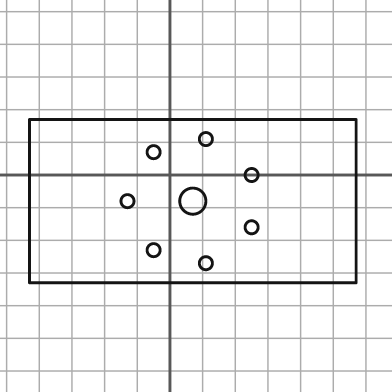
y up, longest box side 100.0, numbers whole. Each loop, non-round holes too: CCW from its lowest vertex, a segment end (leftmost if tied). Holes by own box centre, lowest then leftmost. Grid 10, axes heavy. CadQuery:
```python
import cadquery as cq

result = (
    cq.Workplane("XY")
    .moveTo(-43.0, -33.0)
    .lineTo(57.0, -33.0)
    .lineTo(57.0, 17.0)
    .lineTo(-43.0, 17.0)
    .close()
    .moveTo(11.0, -27.0)
    .circle(2.0)
    .moveTo(-5.0, -23.0)
    .circle(2.0)
    .moveTo(25.0, -16.0)
    .circle(2.0)
    .moveTo(-13.0, -8.0)
    .circle(2.0)
    .moveTo(7.0, -8.0)
    .circle(4.0)
    .moveTo(25.0, 0.0)
    .circle(2.0)
    .moveTo(-5.0, 7.0)
    .circle(2.0)
    .moveTo(11.0, 11.0)
    .circle(2.0)
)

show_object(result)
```